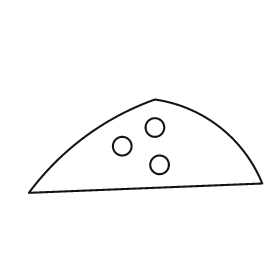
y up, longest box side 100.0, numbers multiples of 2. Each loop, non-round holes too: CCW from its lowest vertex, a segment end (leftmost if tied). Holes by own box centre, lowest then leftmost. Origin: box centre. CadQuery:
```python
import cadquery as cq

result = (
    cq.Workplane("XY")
    .moveTo(-50.0, -20.0)
    .lineTo(50.0, -16.0)
    .threePointArc((32.0, 8.0), (4.0, 20.0))
    .threePointArc((-26.0, 4.0), (-50.0, -20.0))
    .close()
    .moveTo(6.0, -8.0)
    .circle(4.0)
    .moveTo(-10.0, 0.0)
    .circle(4.0)
    .moveTo(4.0, 8.0)
    .circle(4.0)
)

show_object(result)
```